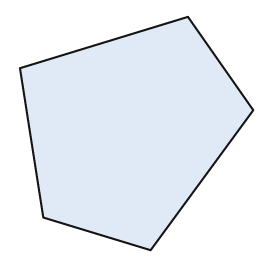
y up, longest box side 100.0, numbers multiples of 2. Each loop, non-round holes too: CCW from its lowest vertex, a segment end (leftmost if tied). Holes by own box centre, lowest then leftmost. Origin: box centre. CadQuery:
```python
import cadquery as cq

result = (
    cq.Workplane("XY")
    .moveTo(6.0, -50.0)
    .lineTo(50.0, 10.0)
    .lineTo(22.0, 50.0)
    .lineTo(-50.0, 28.0)
    .lineTo(-40.0, -36.0)
    .close()
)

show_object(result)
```